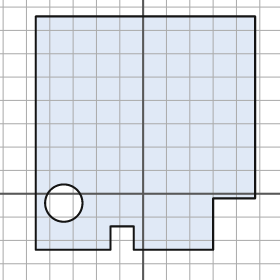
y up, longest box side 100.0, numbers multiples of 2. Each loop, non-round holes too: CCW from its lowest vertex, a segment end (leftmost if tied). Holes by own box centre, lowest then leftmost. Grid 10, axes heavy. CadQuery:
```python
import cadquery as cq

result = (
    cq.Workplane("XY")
    .moveTo(-46.0, -24.0)
    .lineTo(-14.0, -24.0)
    .lineTo(-14.0, -14.0)
    .lineTo(-4.0, -14.0)
    .lineTo(-4.0, -24.0)
    .lineTo(30.0, -24.0)
    .lineTo(30.0, -2.0)
    .lineTo(48.0, -2.0)
    .lineTo(48.0, 76.0)
    .lineTo(-46.0, 76.0)
    .close()
    .moveTo(-34.0, -4.0)
    .circle(8.0)
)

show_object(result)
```